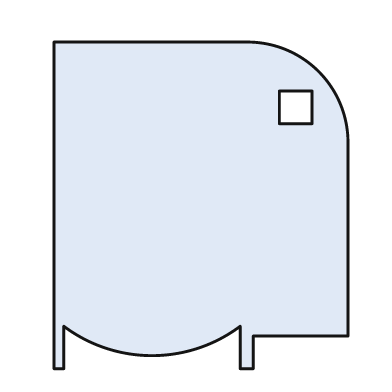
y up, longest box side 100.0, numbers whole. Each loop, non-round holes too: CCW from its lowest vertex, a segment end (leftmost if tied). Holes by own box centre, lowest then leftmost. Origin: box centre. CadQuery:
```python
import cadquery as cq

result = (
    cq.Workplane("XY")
    .moveTo(-45.0, -50.0)
    .lineTo(-42.0, -50.0)
    .lineTo(-42.0, -37.0)
    .threePointArc((-15.0, -46.0), (12.0, -37.0))
    .lineTo(12.0, -50.0)
    .lineTo(16.0, -50.0)
    .lineTo(16.0, -40.0)
    .lineTo(45.0, -40.0)
    .lineTo(45.0, 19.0)
    .threePointArc((36.0, 41.0), (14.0, 50.0))
    .lineTo(-45.0, 50.0)
    .close()
    .moveTo(24.0, 25.0)
    .lineTo(34.0, 25.0)
    .lineTo(34.0, 35.0)
    .lineTo(24.0, 35.0)
    .close()
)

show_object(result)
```